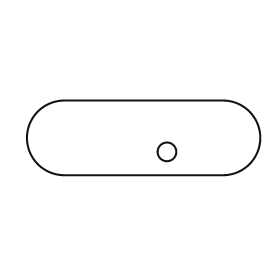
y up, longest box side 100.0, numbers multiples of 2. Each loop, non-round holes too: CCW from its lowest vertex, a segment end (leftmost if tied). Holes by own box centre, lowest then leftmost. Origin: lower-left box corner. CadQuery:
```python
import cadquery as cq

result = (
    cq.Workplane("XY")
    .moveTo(16.0, 0.0)
    .lineTo(84.0, 0.0)
    .threePointArc((100.0, 16.0), (84.0, 32.0))
    .lineTo(16.0, 32.0)
    .threePointArc((0.0, 16.0), (16.0, 0.0))
    .close()
    .moveTo(60.0, 10.0)
    .circle(4.0)
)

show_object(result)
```